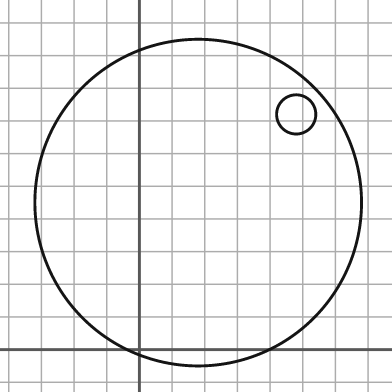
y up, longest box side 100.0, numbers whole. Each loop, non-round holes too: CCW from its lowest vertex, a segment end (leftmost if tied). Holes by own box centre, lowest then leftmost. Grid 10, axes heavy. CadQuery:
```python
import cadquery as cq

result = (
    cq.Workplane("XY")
    .moveTo(18.0, 45.0)
    .circle(50.0)
    .moveTo(48.0, 72.0)
    .circle(6.0)
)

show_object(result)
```